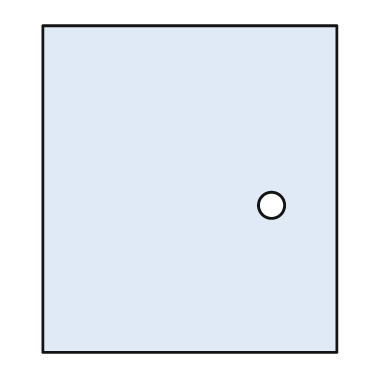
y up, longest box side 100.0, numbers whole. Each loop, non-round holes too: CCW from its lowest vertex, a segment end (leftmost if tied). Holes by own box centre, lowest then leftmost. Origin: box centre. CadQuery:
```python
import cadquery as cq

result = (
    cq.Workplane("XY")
    .moveTo(-45.0, -50.0)
    .lineTo(45.0, -50.0)
    .lineTo(45.0, 50.0)
    .lineTo(-45.0, 50.0)
    .close()
    .moveTo(25.0, -5.0)
    .circle(4.0)
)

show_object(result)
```